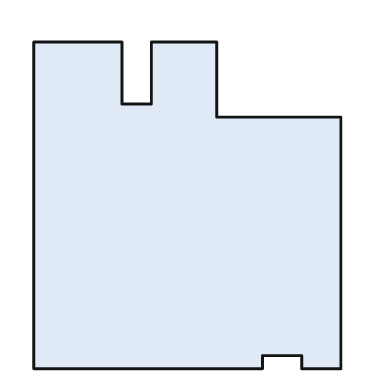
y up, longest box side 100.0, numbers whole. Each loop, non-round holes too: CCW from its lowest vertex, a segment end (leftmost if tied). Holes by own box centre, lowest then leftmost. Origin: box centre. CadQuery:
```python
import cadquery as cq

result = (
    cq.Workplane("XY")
    .moveTo(-47.0, -50.0)
    .lineTo(23.0, -50.0)
    .lineTo(23.0, -46.0)
    .lineTo(35.0, -46.0)
    .lineTo(35.0, -50.0)
    .lineTo(47.0, -50.0)
    .lineTo(47.0, 27.0)
    .lineTo(9.0, 27.0)
    .lineTo(9.0, 50.0)
    .lineTo(-11.0, 50.0)
    .lineTo(-11.0, 31.0)
    .lineTo(-20.0, 31.0)
    .lineTo(-20.0, 50.0)
    .lineTo(-47.0, 50.0)
    .close()
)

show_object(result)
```